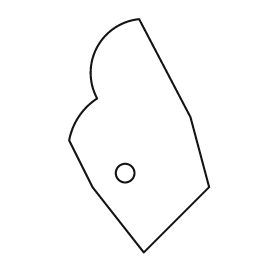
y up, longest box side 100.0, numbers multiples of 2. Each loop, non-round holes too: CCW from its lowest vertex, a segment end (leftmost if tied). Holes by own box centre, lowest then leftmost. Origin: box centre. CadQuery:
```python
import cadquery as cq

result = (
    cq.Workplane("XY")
    .moveTo(2.0, -50.0)
    .lineTo(30.0, -22.0)
    .lineTo(22.0, 8.0)
    .lineTo(0.0, 50.0)
    .threePointArc((-18.0, 38.0), (-18.0, 16.0))
    .threePointArc((-26.0, 8.0), (-30.0, -2.0))
    .lineTo(-20.0, -22.0)
    .close()
    .moveTo(-6.0, -16.0)
    .circle(4.0)
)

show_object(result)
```